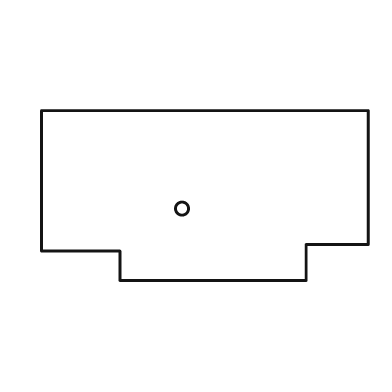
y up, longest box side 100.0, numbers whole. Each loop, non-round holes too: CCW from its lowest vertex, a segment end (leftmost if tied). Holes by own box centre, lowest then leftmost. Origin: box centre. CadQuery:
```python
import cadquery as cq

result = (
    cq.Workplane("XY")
    .moveTo(-26.0, -26.0)
    .lineTo(31.0, -26.0)
    .lineTo(31.0, -15.0)
    .lineTo(50.0, -15.0)
    .lineTo(50.0, 26.0)
    .lineTo(-50.0, 26.0)
    .lineTo(-50.0, -17.0)
    .lineTo(-26.0, -17.0)
    .close()
    .moveTo(-7.0, -4.0)
    .circle(2.0)
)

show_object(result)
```